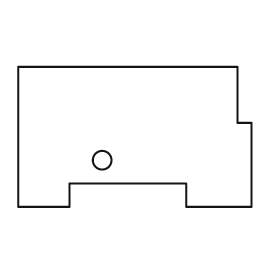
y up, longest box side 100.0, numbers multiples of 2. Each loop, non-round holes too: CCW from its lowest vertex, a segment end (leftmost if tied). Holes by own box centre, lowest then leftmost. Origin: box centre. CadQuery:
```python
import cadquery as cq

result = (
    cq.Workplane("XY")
    .moveTo(-50.0, -30.0)
    .lineTo(-28.0, -30.0)
    .lineTo(-28.0, -20.0)
    .lineTo(22.0, -20.0)
    .lineTo(22.0, -30.0)
    .lineTo(50.0, -30.0)
    .lineTo(50.0, 6.0)
    .lineTo(44.0, 6.0)
    .lineTo(44.0, 30.0)
    .lineTo(-50.0, 30.0)
    .close()
    .moveTo(-14.0, -10.0)
    .circle(4.0)
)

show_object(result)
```